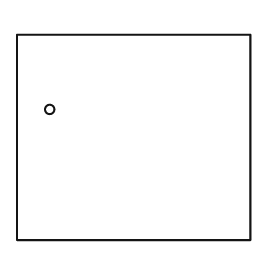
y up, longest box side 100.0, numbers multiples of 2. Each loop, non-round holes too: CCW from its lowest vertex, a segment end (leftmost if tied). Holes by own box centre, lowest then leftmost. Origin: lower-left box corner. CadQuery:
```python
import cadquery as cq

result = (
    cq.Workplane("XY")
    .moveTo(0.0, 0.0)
    .lineTo(100.0, 0.0)
    .lineTo(100.0, 88.0)
    .lineTo(0.0, 88.0)
    .close()
    .moveTo(14.0, 56.0)
    .circle(2.0)
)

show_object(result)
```